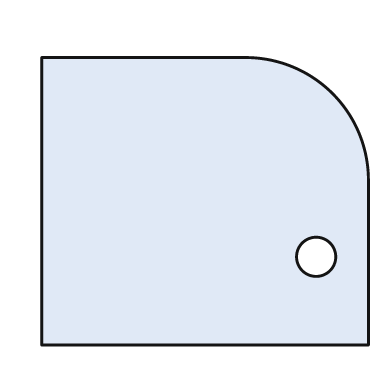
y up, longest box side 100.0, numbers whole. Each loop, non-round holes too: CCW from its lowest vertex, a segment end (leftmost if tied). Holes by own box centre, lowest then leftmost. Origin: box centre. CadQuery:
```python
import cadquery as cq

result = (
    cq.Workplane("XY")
    .moveTo(-50.0, -44.0)
    .lineTo(50.0, -44.0)
    .lineTo(50.0, 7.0)
    .threePointArc((39.0, 33.0), (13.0, 44.0))
    .lineTo(-50.0, 44.0)
    .close()
    .moveTo(34.0, -17.0)
    .circle(6.0)
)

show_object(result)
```